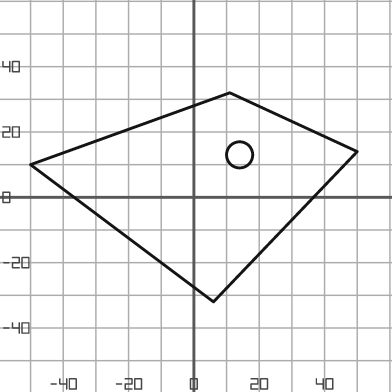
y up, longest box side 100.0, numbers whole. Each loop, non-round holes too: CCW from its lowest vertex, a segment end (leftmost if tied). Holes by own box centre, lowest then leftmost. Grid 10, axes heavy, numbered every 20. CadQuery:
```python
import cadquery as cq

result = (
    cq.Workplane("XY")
    .moveTo(6.0, -32.0)
    .lineTo(50.0, 14.0)
    .lineTo(11.0, 32.0)
    .lineTo(-50.0, 10.0)
    .close()
    .moveTo(14.0, 13.0)
    .circle(4.0)
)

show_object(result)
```